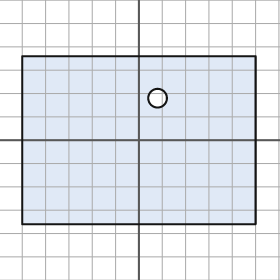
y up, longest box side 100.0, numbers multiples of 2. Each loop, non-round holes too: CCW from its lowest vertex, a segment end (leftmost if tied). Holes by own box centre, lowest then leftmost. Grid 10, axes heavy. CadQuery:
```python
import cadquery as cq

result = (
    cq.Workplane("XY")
    .moveTo(-50.0, -36.0)
    .lineTo(50.0, -36.0)
    .lineTo(50.0, 36.0)
    .lineTo(-50.0, 36.0)
    .close()
    .moveTo(8.0, 18.0)
    .circle(4.0)
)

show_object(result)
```